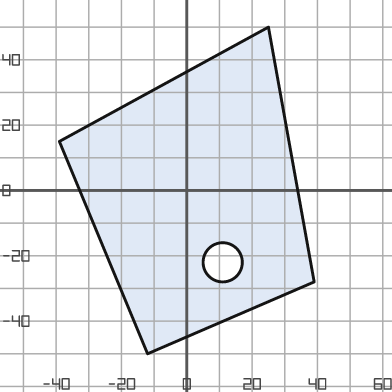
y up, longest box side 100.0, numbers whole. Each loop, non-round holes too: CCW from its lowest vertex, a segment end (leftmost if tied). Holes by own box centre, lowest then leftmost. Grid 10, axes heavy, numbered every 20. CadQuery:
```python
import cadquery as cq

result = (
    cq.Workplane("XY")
    .moveTo(-12.0, -50.0)
    .lineTo(39.0, -28.0)
    .lineTo(25.0, 50.0)
    .lineTo(-39.0, 15.0)
    .close()
    .moveTo(11.0, -22.0)
    .circle(6.0)
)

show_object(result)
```